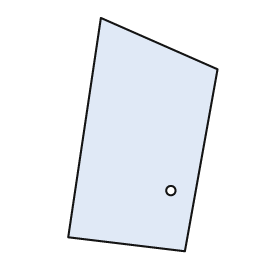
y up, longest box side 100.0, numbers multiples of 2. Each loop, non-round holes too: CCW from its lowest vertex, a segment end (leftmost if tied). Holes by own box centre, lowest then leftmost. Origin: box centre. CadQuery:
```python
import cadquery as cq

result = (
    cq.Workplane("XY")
    .moveTo(18.0, -50.0)
    .lineTo(32.0, 28.0)
    .lineTo(-18.0, 50.0)
    .lineTo(-32.0, -44.0)
    .close()
    .moveTo(12.0, -24.0)
    .circle(2.0)
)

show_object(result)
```